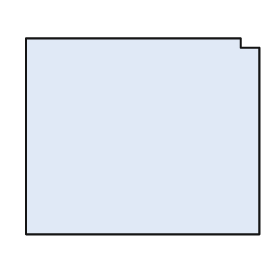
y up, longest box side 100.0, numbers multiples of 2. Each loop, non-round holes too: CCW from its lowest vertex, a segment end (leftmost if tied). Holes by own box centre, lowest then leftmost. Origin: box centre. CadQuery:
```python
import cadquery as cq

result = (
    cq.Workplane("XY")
    .moveTo(-50.0, -42.0)
    .lineTo(50.0, -42.0)
    .lineTo(50.0, 38.0)
    .lineTo(42.0, 38.0)
    .lineTo(42.0, 42.0)
    .lineTo(-50.0, 42.0)
    .close()
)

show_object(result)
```